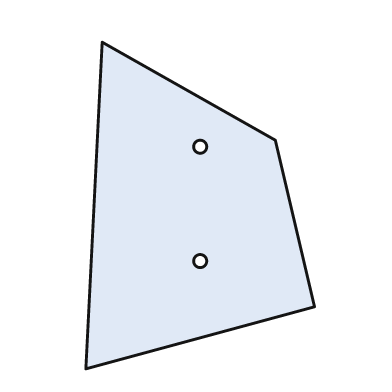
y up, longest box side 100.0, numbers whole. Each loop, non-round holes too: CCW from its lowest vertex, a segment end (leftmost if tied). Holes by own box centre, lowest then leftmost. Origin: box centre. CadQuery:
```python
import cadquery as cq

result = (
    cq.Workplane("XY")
    .moveTo(-35.0, -50.0)
    .lineTo(35.0, -31.0)
    .lineTo(23.0, 20.0)
    .lineTo(-30.0, 50.0)
    .close()
    .moveTo(0.0, -17.0)
    .circle(2.0)
    .moveTo(0.0, 18.0)
    .circle(2.0)
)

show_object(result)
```